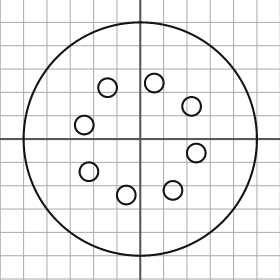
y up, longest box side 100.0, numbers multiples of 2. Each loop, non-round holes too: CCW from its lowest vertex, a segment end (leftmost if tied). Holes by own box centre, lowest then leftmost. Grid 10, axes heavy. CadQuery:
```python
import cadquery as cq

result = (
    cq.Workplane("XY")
    .moveTo(0.0, 0.0)
    .circle(50.0)
    .moveTo(-6.0, -24.0)
    .circle(4.0)
    .moveTo(14.0, -22.0)
    .circle(4.0)
    .moveTo(-22.0, -14.0)
    .circle(4.0)
    .moveTo(24.0, -6.0)
    .circle(4.0)
    .moveTo(-24.0, 6.0)
    .circle(4.0)
    .moveTo(22.0, 14.0)
    .circle(4.0)
    .moveTo(-14.0, 22.0)
    .circle(4.0)
    .moveTo(6.0, 24.0)
    .circle(4.0)
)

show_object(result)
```